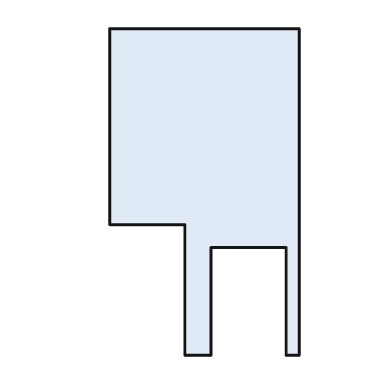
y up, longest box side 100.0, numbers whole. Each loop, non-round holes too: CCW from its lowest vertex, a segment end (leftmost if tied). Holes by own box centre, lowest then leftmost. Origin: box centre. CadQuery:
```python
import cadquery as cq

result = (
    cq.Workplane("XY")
    .moveTo(-6.0, -50.0)
    .lineTo(2.0, -50.0)
    .lineTo(2.0, -17.0)
    .lineTo(25.0, -17.0)
    .lineTo(25.0, -50.0)
    .lineTo(29.0, -50.0)
    .lineTo(29.0, 50.0)
    .lineTo(-29.0, 50.0)
    .lineTo(-29.0, -10.0)
    .lineTo(-6.0, -10.0)
    .close()
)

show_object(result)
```